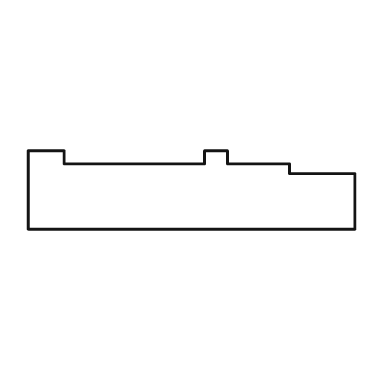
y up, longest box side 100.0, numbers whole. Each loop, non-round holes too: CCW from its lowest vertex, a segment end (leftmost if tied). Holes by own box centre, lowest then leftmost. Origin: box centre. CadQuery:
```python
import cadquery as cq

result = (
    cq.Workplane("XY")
    .moveTo(-50.0, -12.0)
    .lineTo(50.0, -12.0)
    .lineTo(50.0, 5.0)
    .lineTo(30.0, 5.0)
    .lineTo(30.0, 8.0)
    .lineTo(11.0, 8.0)
    .lineTo(11.0, 12.0)
    .lineTo(4.0, 12.0)
    .lineTo(4.0, 8.0)
    .lineTo(-39.0, 8.0)
    .lineTo(-39.0, 12.0)
    .lineTo(-50.0, 12.0)
    .close()
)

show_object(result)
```